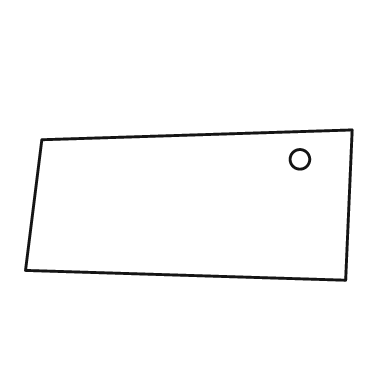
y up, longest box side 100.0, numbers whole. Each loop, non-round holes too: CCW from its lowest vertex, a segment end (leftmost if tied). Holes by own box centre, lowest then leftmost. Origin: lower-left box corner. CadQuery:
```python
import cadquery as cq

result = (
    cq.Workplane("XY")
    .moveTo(98.0, 0.0)
    .lineTo(100.0, 46.0)
    .lineTo(5.0, 43.0)
    .lineTo(0.0, 3.0)
    .close()
    .moveTo(84.0, 37.0)
    .circle(3.0)
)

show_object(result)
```